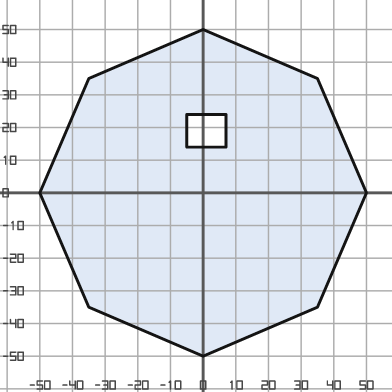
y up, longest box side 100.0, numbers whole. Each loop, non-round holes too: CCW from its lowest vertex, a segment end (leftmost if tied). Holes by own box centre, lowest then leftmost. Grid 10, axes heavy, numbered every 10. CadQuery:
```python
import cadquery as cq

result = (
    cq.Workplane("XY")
    .moveTo(0.0, -50.0)
    .lineTo(35.0, -35.0)
    .lineTo(50.0, 0.0)
    .lineTo(35.0, 35.0)
    .lineTo(0.0, 50.0)
    .lineTo(-35.0, 35.0)
    .lineTo(-50.0, 0.0)
    .lineTo(-35.0, -35.0)
    .close()
    .moveTo(-5.0, 14.0)
    .lineTo(7.0, 14.0)
    .lineTo(7.0, 24.0)
    .lineTo(-5.0, 24.0)
    .close()
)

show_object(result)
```